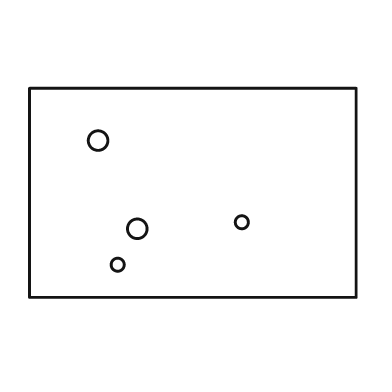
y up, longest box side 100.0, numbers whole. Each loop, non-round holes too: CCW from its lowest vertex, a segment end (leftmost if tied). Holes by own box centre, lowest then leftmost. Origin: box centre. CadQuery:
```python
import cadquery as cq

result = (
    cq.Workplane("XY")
    .moveTo(-50.0, -32.0)
    .lineTo(50.0, -32.0)
    .lineTo(50.0, 32.0)
    .lineTo(-50.0, 32.0)
    .close()
    .moveTo(-23.0, -22.0)
    .circle(2.0)
    .moveTo(-17.0, -11.0)
    .circle(3.0)
    .moveTo(15.0, -9.0)
    .circle(2.0)
    .moveTo(-29.0, 16.0)
    .circle(3.0)
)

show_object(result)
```